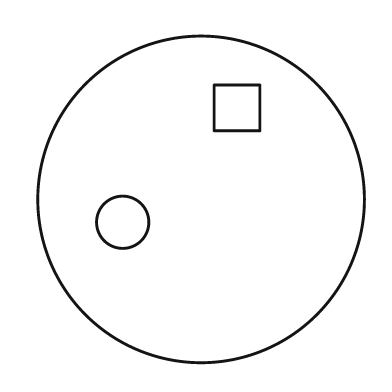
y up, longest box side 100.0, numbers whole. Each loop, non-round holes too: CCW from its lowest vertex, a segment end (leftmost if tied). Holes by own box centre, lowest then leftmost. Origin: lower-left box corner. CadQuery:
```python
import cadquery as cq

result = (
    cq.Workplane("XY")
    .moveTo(50.0, 50.0)
    .circle(50.0)
    .moveTo(26.0, 43.0)
    .circle(8.0)
    .moveTo(54.0, 71.0)
    .lineTo(68.0, 71.0)
    .lineTo(68.0, 85.0)
    .lineTo(54.0, 85.0)
    .close()
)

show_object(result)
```